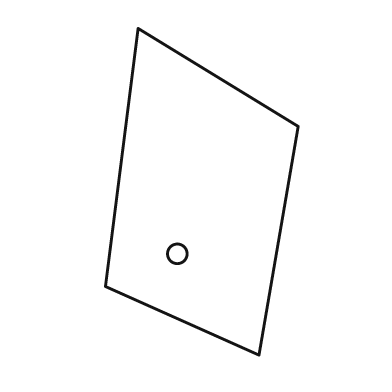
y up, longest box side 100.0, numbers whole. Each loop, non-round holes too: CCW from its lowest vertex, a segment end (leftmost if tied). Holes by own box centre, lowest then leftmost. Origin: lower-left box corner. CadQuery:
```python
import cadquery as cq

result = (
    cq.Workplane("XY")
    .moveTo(47.0, 0.0)
    .lineTo(59.0, 70.0)
    .lineTo(10.0, 100.0)
    .lineTo(0.0, 21.0)
    .close()
    .moveTo(22.0, 31.0)
    .circle(3.0)
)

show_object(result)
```